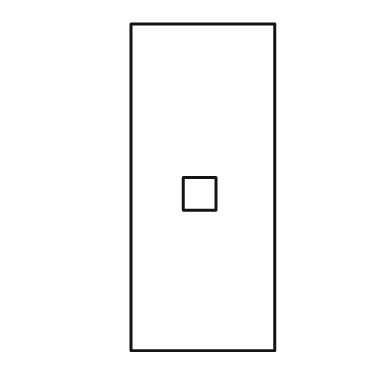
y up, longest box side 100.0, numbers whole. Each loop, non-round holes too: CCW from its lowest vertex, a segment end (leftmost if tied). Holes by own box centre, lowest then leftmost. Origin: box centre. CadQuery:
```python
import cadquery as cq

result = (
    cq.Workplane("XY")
    .moveTo(-22.0, -50.0)
    .lineTo(22.0, -50.0)
    .lineTo(22.0, 50.0)
    .lineTo(-22.0, 50.0)
    .close()
    .moveTo(-6.0, -7.0)
    .lineTo(4.0, -7.0)
    .lineTo(4.0, 3.0)
    .lineTo(-6.0, 3.0)
    .close()
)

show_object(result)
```